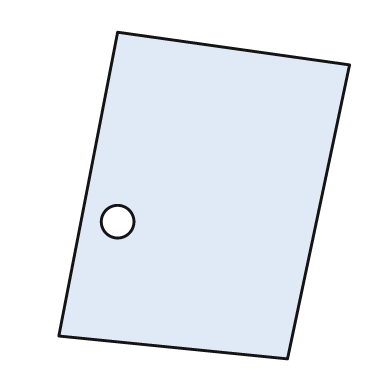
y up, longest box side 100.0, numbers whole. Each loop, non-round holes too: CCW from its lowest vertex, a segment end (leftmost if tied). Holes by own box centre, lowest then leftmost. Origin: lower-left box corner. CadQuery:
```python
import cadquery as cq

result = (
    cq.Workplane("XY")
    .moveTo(70.0, 0.0)
    .lineTo(89.0, 90.0)
    .lineTo(18.0, 100.0)
    .lineTo(0.0, 7.0)
    .close()
    .moveTo(18.0, 42.0)
    .circle(5.0)
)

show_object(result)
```